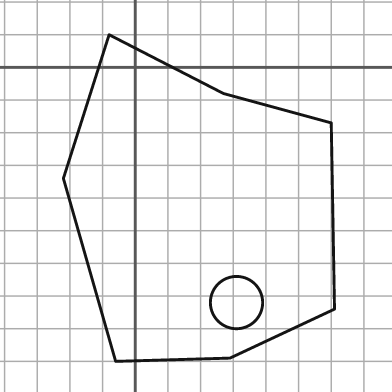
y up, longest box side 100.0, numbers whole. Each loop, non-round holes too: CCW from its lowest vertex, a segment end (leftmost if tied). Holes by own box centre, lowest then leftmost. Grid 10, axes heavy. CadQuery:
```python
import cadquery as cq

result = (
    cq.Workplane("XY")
    .moveTo(-6.0, -90.0)
    .lineTo(29.0, -89.0)
    .lineTo(61.0, -74.0)
    .lineTo(60.0, -17.0)
    .lineTo(27.0, -8.0)
    .lineTo(-8.0, 10.0)
    .lineTo(-22.0, -34.0)
    .close()
    .moveTo(31.0, -72.0)
    .circle(8.0)
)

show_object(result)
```